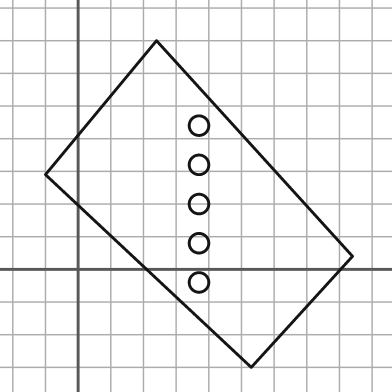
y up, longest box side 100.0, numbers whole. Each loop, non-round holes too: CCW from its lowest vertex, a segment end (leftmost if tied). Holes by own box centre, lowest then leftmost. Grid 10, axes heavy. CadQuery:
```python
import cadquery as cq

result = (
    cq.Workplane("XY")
    .moveTo(53.0, -30.0)
    .lineTo(84.0, 4.0)
    .lineTo(24.0, 70.0)
    .lineTo(-10.0, 29.0)
    .close()
    .moveTo(37.0, -4.0)
    .circle(3.0)
    .moveTo(37.0, 8.0)
    .circle(3.0)
    .moveTo(37.0, 20.0)
    .circle(3.0)
    .moveTo(37.0, 32.0)
    .circle(3.0)
    .moveTo(37.0, 44.0)
    .circle(3.0)
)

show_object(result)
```